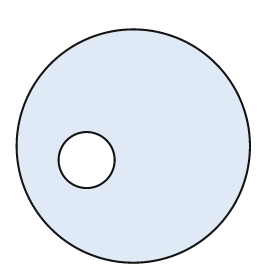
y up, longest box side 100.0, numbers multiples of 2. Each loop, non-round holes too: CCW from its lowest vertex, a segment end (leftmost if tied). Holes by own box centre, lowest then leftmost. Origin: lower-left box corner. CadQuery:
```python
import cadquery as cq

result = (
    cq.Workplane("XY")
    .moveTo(50.0, 50.0)
    .circle(50.0)
    .moveTo(30.0, 44.0)
    .circle(12.0)
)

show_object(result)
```